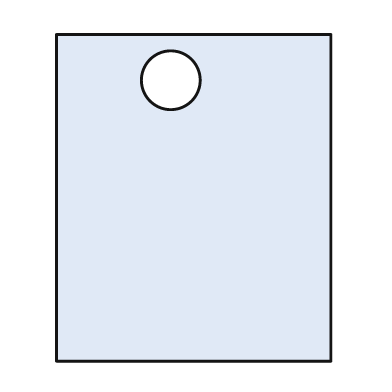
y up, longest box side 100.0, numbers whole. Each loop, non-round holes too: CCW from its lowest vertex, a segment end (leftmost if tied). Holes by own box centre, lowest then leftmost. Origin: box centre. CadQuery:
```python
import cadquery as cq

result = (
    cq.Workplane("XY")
    .moveTo(-42.0, -50.0)
    .lineTo(42.0, -50.0)
    .lineTo(42.0, 50.0)
    .lineTo(-42.0, 50.0)
    .close()
    .moveTo(-7.0, 36.0)
    .circle(9.0)
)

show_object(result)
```